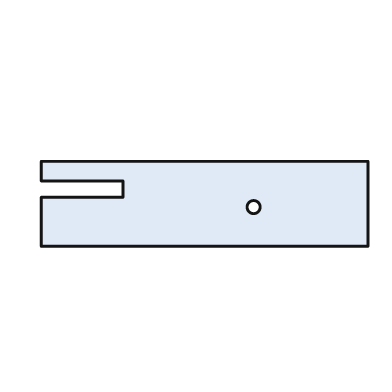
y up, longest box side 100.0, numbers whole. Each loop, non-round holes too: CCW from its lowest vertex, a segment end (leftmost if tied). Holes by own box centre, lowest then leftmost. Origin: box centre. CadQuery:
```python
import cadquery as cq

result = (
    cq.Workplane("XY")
    .moveTo(-50.0, -13.0)
    .lineTo(50.0, -13.0)
    .lineTo(50.0, 13.0)
    .lineTo(-50.0, 13.0)
    .lineTo(-50.0, 7.0)
    .lineTo(-25.0, 7.0)
    .lineTo(-25.0, 2.0)
    .lineTo(-50.0, 2.0)
    .close()
    .moveTo(15.0, -1.0)
    .circle(2.0)
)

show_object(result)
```